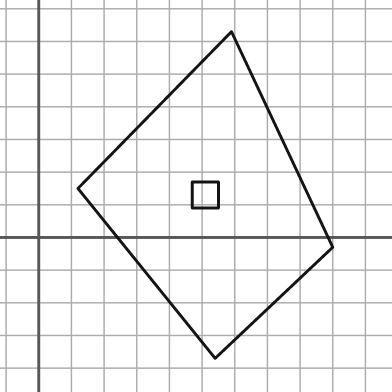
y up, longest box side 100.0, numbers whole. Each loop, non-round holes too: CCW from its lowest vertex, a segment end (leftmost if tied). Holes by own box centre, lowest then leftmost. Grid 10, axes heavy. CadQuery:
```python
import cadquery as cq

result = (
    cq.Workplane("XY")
    .moveTo(54.0, -37.0)
    .lineTo(90.0, -3.0)
    .lineTo(59.0, 63.0)
    .lineTo(12.0, 15.0)
    .close()
    .moveTo(47.0, 9.0)
    .lineTo(55.0, 9.0)
    .lineTo(55.0, 17.0)
    .lineTo(47.0, 17.0)
    .close()
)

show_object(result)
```